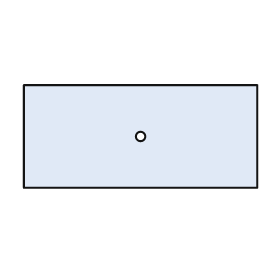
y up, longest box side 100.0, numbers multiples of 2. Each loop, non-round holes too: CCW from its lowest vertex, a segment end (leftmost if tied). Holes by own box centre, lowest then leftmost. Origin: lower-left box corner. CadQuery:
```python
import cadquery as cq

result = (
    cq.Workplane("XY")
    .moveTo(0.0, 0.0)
    .lineTo(100.0, 0.0)
    .lineTo(100.0, 44.0)
    .lineTo(0.0, 44.0)
    .close()
    .moveTo(50.0, 22.0)
    .circle(2.0)
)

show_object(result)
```